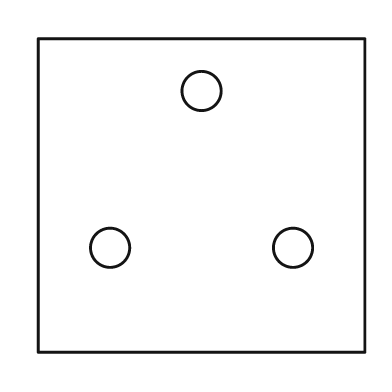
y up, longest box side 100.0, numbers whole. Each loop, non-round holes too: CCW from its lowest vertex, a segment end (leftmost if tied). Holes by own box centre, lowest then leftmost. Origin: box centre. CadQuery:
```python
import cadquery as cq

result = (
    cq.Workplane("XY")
    .moveTo(-50.0, -48.0)
    .lineTo(50.0, -48.0)
    .lineTo(50.0, 48.0)
    .lineTo(-50.0, 48.0)
    .close()
    .moveTo(-28.0, -16.0)
    .circle(6.0)
    .moveTo(28.0, -16.0)
    .circle(6.0)
    .moveTo(0.0, 32.0)
    .circle(6.0)
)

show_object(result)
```